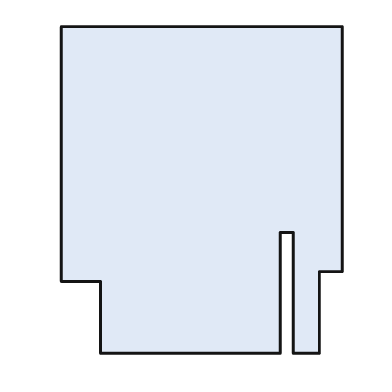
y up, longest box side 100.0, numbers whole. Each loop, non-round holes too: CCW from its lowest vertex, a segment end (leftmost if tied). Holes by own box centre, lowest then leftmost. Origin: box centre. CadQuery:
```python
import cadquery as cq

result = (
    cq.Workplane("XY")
    .moveTo(-31.0, -50.0)
    .lineTo(24.0, -50.0)
    .lineTo(24.0, -13.0)
    .lineTo(28.0, -13.0)
    .lineTo(28.0, -50.0)
    .lineTo(36.0, -50.0)
    .lineTo(36.0, -25.0)
    .lineTo(43.0, -25.0)
    .lineTo(43.0, 50.0)
    .lineTo(-43.0, 50.0)
    .lineTo(-43.0, -28.0)
    .lineTo(-31.0, -28.0)
    .close()
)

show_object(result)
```